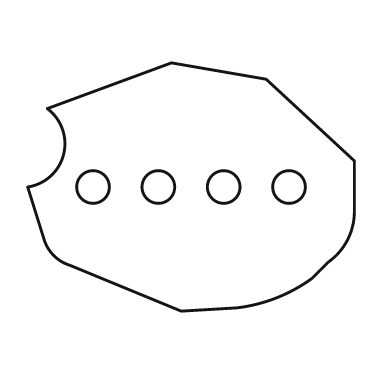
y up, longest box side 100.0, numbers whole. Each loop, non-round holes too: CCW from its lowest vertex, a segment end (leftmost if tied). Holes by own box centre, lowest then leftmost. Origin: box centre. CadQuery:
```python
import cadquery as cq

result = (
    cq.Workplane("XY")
    .moveTo(-3.0, -38.0)
    .lineTo(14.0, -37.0)
    .threePointArc((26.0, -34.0), (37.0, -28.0))
    .lineTo(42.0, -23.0)
    .threePointArc((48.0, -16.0), (50.0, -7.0))
    .lineTo(50.0, 8.0)
    .lineTo(23.0, 33.0)
    .lineTo(-6.0, 38.0)
    .lineTo(-44.0, 24.0)
    .threePointArc((-39.0, 10.0), (-50.0, 0.0))
    .lineTo(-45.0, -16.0)
    .threePointArc((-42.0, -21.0), (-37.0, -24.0))
    .close()
    .moveTo(-30.0, 0.0)
    .circle(5.0)
    .moveTo(-10.0, 0.0)
    .circle(5.0)
    .moveTo(10.0, 0.0)
    .circle(5.0)
    .moveTo(30.0, 0.0)
    .circle(5.0)
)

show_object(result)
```